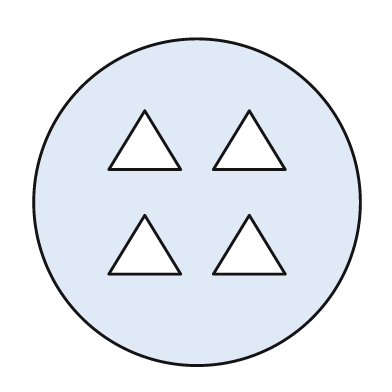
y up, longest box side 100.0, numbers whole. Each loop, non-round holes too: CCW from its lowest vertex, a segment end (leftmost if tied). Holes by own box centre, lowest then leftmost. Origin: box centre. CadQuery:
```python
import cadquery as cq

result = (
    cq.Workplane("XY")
    .moveTo(0.0, 0.0)
    .circle(50.0)
    .moveTo(-27.0, -22.0)
    .lineTo(-5.0, -22.0)
    .lineTo(-16.0, -4.0)
    .close()
    .moveTo(5.0, -22.0)
    .lineTo(27.0, -22.0)
    .lineTo(16.0, -4.0)
    .close()
    .moveTo(-27.0, 10.0)
    .lineTo(-5.0, 10.0)
    .lineTo(-16.0, 28.0)
    .close()
    .moveTo(5.0, 10.0)
    .lineTo(27.0, 10.0)
    .lineTo(16.0, 28.0)
    .close()
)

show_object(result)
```